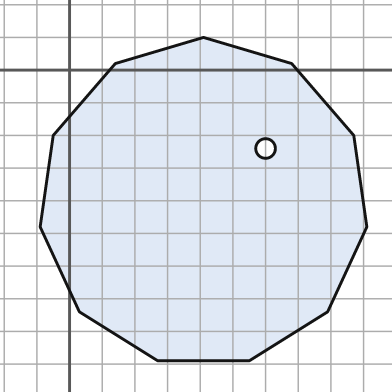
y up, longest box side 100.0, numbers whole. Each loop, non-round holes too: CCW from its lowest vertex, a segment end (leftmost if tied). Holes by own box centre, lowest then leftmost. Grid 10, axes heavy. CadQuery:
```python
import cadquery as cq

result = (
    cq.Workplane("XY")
    .moveTo(27.0, -89.0)
    .lineTo(55.0, -89.0)
    .lineTo(79.0, -74.0)
    .lineTo(91.0, -48.0)
    .lineTo(87.0, -20.0)
    .lineTo(68.0, 2.0)
    .lineTo(41.0, 10.0)
    .lineTo(14.0, 2.0)
    .lineTo(-5.0, -20.0)
    .lineTo(-9.0, -48.0)
    .lineTo(3.0, -74.0)
    .close()
    .moveTo(60.0, -24.0)
    .circle(3.0)
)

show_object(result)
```